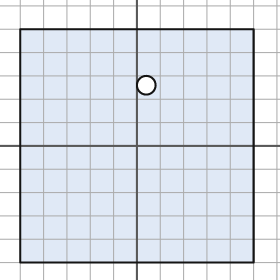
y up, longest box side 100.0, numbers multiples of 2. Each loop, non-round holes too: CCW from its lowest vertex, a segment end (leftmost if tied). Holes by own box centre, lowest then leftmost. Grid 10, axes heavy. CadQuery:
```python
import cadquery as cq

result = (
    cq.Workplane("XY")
    .moveTo(-50.0, -50.0)
    .lineTo(50.0, -50.0)
    .lineTo(50.0, 50.0)
    .lineTo(-50.0, 50.0)
    .close()
    .moveTo(4.0, 26.0)
    .circle(4.0)
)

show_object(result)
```